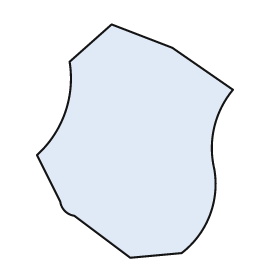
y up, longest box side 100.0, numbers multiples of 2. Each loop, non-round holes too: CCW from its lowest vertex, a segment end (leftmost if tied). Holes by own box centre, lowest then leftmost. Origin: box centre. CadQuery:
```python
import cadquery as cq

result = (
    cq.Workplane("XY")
    .moveTo(-2.0, -50.0)
    .lineTo(20.0, -48.0)
    .threePointArc((32.0, -32.0), (34.0, -12.0))
    .threePointArc((34.0, 6.0), (42.0, 22.0))
    .lineTo(16.0, 40.0)
    .lineTo(-10.0, 50.0)
    .lineTo(-28.0, 34.0)
    .threePointArc((-30.0, 12.0), (-42.0, -6.0))
    .lineTo(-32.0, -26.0)
    .threePointArc((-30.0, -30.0), (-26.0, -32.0))
    .close()
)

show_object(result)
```